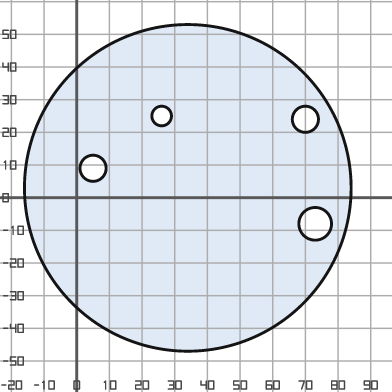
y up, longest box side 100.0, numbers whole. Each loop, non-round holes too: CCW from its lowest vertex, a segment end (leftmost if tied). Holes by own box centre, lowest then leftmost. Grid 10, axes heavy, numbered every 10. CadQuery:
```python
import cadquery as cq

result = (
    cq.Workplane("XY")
    .moveTo(34.0, 3.0)
    .circle(50.0)
    .moveTo(73.0, -8.0)
    .circle(5.0)
    .moveTo(5.0, 9.0)
    .circle(4.0)
    .moveTo(70.0, 24.0)
    .circle(4.0)
    .moveTo(26.0, 25.0)
    .circle(3.0)
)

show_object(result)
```